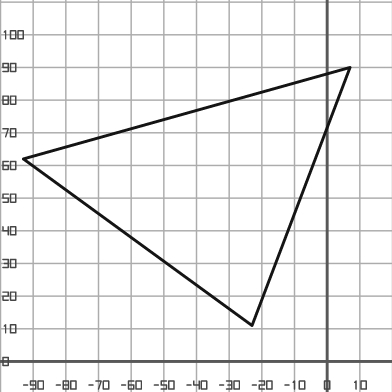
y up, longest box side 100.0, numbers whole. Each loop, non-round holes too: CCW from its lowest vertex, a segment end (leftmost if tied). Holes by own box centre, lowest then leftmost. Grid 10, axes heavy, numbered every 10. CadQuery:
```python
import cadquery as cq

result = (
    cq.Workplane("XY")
    .moveTo(-23.0, 11.0)
    .lineTo(7.0, 90.0)
    .lineTo(-93.0, 62.0)
    .close()
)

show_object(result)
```